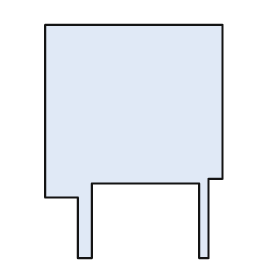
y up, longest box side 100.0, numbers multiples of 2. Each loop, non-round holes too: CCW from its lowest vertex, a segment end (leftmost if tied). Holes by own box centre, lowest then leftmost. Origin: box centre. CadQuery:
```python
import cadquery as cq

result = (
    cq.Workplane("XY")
    .moveTo(-24.0, -50.0)
    .lineTo(-18.0, -50.0)
    .lineTo(-18.0, -18.0)
    .lineTo(28.0, -18.0)
    .lineTo(28.0, -50.0)
    .lineTo(32.0, -50.0)
    .lineTo(32.0, -16.0)
    .lineTo(38.0, -16.0)
    .lineTo(38.0, 50.0)
    .lineTo(-38.0, 50.0)
    .lineTo(-38.0, -24.0)
    .lineTo(-24.0, -24.0)
    .close()
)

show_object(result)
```